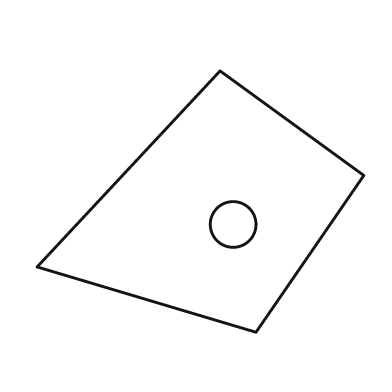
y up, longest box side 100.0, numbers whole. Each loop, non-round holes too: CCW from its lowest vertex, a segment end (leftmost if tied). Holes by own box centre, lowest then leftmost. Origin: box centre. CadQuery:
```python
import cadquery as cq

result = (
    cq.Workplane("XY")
    .moveTo(17.0, -40.0)
    .lineTo(50.0, 8.0)
    .lineTo(6.0, 40.0)
    .lineTo(-50.0, -20.0)
    .close()
    .moveTo(10.0, -7.0)
    .circle(7.0)
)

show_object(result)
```